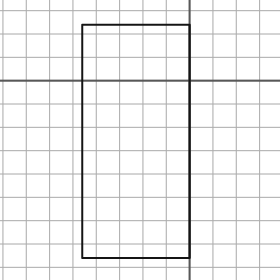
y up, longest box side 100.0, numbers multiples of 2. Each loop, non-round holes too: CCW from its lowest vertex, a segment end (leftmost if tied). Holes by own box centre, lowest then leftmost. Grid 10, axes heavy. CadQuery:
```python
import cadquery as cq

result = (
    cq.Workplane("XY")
    .moveTo(-46.0, -76.0)
    .lineTo(0.0, -76.0)
    .lineTo(0.0, 24.0)
    .lineTo(-46.0, 24.0)
    .close()
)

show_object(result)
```